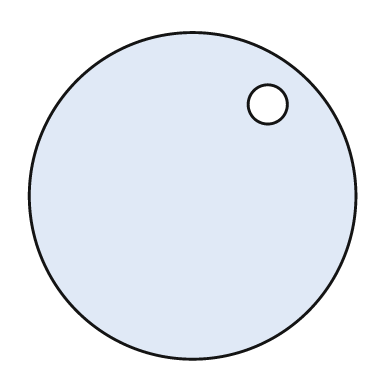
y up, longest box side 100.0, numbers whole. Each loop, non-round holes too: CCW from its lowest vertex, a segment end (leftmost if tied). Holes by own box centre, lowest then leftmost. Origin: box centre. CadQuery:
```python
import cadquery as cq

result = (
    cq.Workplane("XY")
    .moveTo(0.0, 0.0)
    .circle(50.0)
    .moveTo(23.0, 28.0)
    .circle(6.0)
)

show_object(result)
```